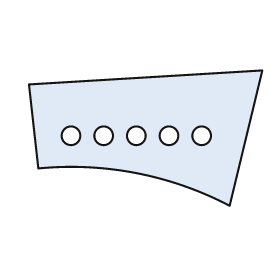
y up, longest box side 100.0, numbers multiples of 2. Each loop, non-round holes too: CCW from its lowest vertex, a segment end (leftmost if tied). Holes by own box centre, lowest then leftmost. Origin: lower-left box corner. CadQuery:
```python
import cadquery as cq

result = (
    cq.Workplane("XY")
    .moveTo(86.0, 0.0)
    .lineTo(100.0, 58.0)
    .lineTo(0.0, 52.0)
    .lineTo(4.0, 16.0)
    .threePointArc((46.0, 14.0), (86.0, 0.0))
    .close()
    .moveTo(18.0, 30.0)
    .circle(4.0)
    .moveTo(32.0, 30.0)
    .circle(4.0)
    .moveTo(46.0, 30.0)
    .circle(4.0)
    .moveTo(60.0, 30.0)
    .circle(4.0)
    .moveTo(74.0, 30.0)
    .circle(4.0)
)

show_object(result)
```